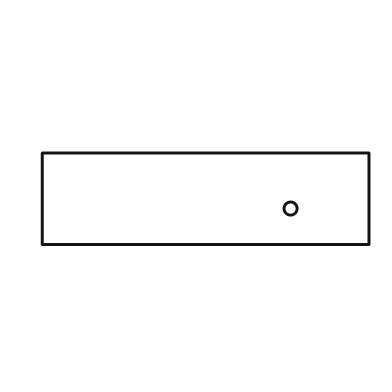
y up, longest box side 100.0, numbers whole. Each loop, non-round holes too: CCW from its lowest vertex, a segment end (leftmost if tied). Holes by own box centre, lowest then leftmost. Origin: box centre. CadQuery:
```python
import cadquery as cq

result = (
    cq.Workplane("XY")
    .moveTo(-50.0, -14.0)
    .lineTo(50.0, -14.0)
    .lineTo(50.0, 14.0)
    .lineTo(-50.0, 14.0)
    .close()
    .moveTo(26.0, -3.0)
    .circle(2.0)
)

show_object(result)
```